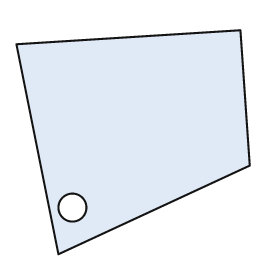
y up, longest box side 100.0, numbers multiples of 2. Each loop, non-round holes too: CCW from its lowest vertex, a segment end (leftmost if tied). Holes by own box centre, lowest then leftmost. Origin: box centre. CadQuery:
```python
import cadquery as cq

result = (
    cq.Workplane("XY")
    .moveTo(-32.0, -48.0)
    .lineTo(50.0, -10.0)
    .lineTo(46.0, 48.0)
    .lineTo(-50.0, 42.0)
    .close()
    .moveTo(-26.0, -28.0)
    .circle(6.0)
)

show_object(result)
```